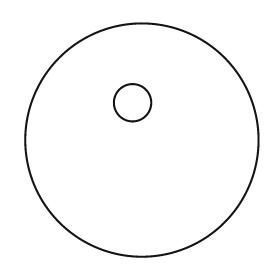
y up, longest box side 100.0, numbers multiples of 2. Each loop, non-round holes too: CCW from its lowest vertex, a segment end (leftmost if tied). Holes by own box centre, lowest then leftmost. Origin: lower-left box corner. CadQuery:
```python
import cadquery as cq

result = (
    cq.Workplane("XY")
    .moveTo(50.0, 50.0)
    .circle(50.0)
    .moveTo(46.0, 66.0)
    .circle(8.0)
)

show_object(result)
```